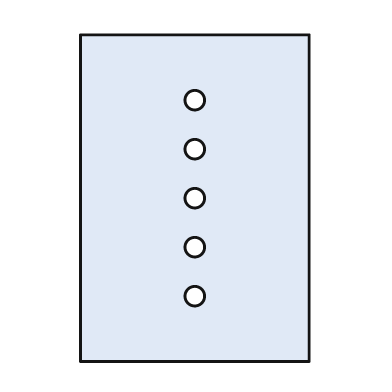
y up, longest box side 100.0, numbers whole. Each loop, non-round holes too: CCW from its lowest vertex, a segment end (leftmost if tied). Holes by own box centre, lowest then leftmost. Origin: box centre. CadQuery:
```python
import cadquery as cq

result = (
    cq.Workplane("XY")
    .moveTo(-35.0, -50.0)
    .lineTo(35.0, -50.0)
    .lineTo(35.0, 50.0)
    .lineTo(-35.0, 50.0)
    .close()
    .moveTo(0.0, -30.0)
    .circle(3.0)
    .moveTo(0.0, -15.0)
    .circle(3.0)
    .moveTo(0.0, 0.0)
    .circle(3.0)
    .moveTo(0.0, 15.0)
    .circle(3.0)
    .moveTo(0.0, 30.0)
    .circle(3.0)
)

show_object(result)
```